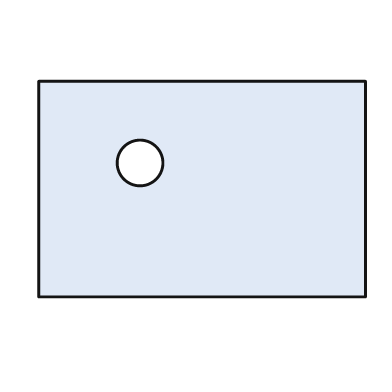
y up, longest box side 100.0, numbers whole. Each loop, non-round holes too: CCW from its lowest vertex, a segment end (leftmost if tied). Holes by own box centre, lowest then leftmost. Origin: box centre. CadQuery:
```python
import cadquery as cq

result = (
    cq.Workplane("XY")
    .moveTo(-50.0, -33.0)
    .lineTo(50.0, -33.0)
    .lineTo(50.0, 33.0)
    .lineTo(-50.0, 33.0)
    .close()
    .moveTo(-19.0, 8.0)
    .circle(7.0)
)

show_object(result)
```